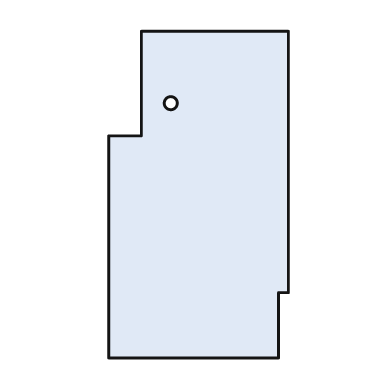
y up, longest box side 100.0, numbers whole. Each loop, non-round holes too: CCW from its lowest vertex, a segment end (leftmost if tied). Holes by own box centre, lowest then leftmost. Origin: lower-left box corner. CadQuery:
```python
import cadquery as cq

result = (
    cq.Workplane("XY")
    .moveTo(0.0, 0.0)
    .lineTo(52.0, 0.0)
    .lineTo(52.0, 20.0)
    .lineTo(55.0, 20.0)
    .lineTo(55.0, 100.0)
    .lineTo(10.0, 100.0)
    .lineTo(10.0, 68.0)
    .lineTo(0.0, 68.0)
    .close()
    .moveTo(19.0, 78.0)
    .circle(2.0)
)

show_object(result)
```